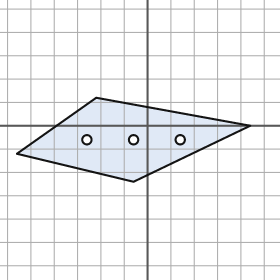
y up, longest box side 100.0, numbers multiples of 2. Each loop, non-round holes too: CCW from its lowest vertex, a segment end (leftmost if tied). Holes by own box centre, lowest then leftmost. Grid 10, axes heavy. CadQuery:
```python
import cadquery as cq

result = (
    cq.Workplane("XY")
    .moveTo(-6.0, -24.0)
    .lineTo(44.0, 0.0)
    .lineTo(-22.0, 12.0)
    .lineTo(-56.0, -12.0)
    .close()
    .moveTo(-26.0, -6.0)
    .circle(2.0)
    .moveTo(-6.0, -6.0)
    .circle(2.0)
    .moveTo(14.0, -6.0)
    .circle(2.0)
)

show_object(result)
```